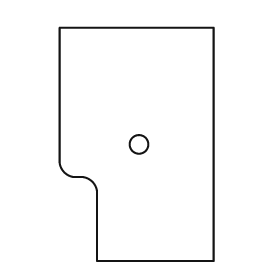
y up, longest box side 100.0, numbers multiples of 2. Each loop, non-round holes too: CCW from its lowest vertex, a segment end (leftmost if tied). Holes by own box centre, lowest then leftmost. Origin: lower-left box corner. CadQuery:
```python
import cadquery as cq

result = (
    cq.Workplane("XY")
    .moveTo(16.0, 0.0)
    .lineTo(66.0, 0.0)
    .lineTo(66.0, 100.0)
    .lineTo(0.0, 100.0)
    .lineTo(0.0, 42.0)
    .threePointArc((2.0, 38.0), (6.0, 36.0))
    .lineTo(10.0, 36.0)
    .threePointArc((14.0, 34.0), (16.0, 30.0))
    .close()
    .moveTo(34.0, 50.0)
    .circle(4.0)
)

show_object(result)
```